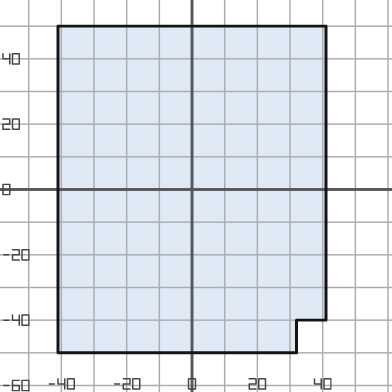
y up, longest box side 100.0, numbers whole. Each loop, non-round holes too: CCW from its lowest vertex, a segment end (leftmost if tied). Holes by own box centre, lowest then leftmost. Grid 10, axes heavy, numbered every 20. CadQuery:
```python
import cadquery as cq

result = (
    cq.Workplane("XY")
    .moveTo(-41.0, -50.0)
    .lineTo(32.0, -50.0)
    .lineTo(32.0, -40.0)
    .lineTo(41.0, -40.0)
    .lineTo(41.0, 50.0)
    .lineTo(-41.0, 50.0)
    .close()
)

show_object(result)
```